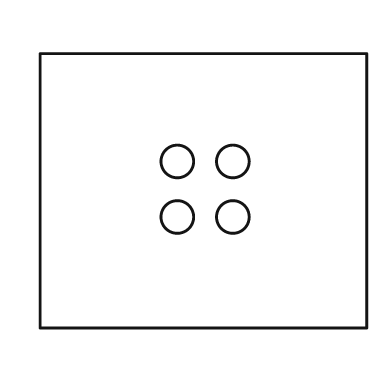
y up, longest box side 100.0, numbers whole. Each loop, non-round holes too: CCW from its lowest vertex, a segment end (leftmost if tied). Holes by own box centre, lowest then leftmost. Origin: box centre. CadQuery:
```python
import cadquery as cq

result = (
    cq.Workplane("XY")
    .moveTo(-50.0, -42.0)
    .lineTo(50.0, -42.0)
    .lineTo(50.0, 42.0)
    .lineTo(-50.0, 42.0)
    .close()
    .moveTo(-8.0, -8.0)
    .circle(5.0)
    .moveTo(9.0, -8.0)
    .circle(5.0)
    .moveTo(-8.0, 9.0)
    .circle(5.0)
    .moveTo(9.0, 9.0)
    .circle(5.0)
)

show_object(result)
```